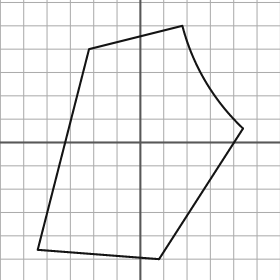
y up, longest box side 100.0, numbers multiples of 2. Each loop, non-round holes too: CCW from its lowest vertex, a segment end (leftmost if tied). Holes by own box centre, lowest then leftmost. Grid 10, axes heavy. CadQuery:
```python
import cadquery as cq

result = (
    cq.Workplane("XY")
    .moveTo(8.0, -50.0)
    .lineTo(44.0, 6.0)
    .threePointArc((28.0, 26.0), (18.0, 50.0))
    .lineTo(-22.0, 40.0)
    .lineTo(-44.0, -46.0)
    .close()
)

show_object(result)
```